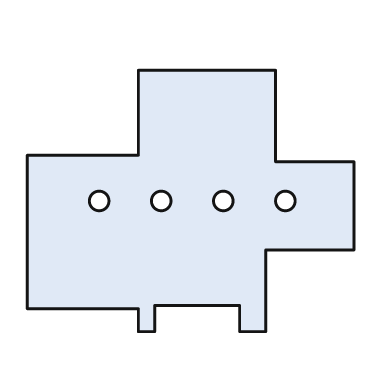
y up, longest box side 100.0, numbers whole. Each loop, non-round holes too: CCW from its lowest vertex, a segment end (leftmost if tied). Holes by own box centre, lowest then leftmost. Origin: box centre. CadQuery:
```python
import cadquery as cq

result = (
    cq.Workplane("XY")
    .moveTo(-16.0, -40.0)
    .lineTo(-11.0, -40.0)
    .lineTo(-11.0, -32.0)
    .lineTo(15.0, -32.0)
    .lineTo(15.0, -40.0)
    .lineTo(23.0, -40.0)
    .lineTo(23.0, -15.0)
    .lineTo(50.0, -15.0)
    .lineTo(50.0, 12.0)
    .lineTo(26.0, 12.0)
    .lineTo(26.0, 40.0)
    .lineTo(-16.0, 40.0)
    .lineTo(-16.0, 14.0)
    .lineTo(-50.0, 14.0)
    .lineTo(-50.0, -33.0)
    .lineTo(-16.0, -33.0)
    .close()
    .moveTo(-28.0, 0.0)
    .circle(3.0)
    .moveTo(-9.0, 0.0)
    .circle(3.0)
    .moveTo(10.0, 0.0)
    .circle(3.0)
    .moveTo(29.0, 0.0)
    .circle(3.0)
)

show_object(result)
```